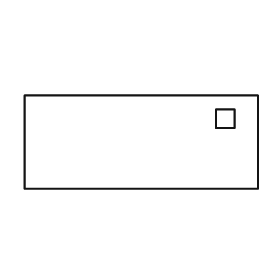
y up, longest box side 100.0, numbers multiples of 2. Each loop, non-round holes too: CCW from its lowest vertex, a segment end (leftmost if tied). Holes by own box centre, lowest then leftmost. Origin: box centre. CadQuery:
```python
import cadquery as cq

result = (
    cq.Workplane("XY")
    .moveTo(-50.0, -20.0)
    .lineTo(50.0, -20.0)
    .lineTo(50.0, 20.0)
    .lineTo(-50.0, 20.0)
    .close()
    .moveTo(32.0, 6.0)
    .lineTo(40.0, 6.0)
    .lineTo(40.0, 14.0)
    .lineTo(32.0, 14.0)
    .close()
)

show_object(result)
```